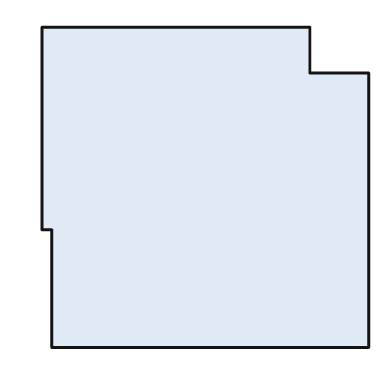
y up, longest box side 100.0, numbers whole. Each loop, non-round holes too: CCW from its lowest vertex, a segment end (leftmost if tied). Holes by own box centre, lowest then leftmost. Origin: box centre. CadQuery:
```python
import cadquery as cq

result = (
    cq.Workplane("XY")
    .moveTo(-47.0, -49.0)
    .lineTo(50.0, -49.0)
    .lineTo(50.0, 35.0)
    .lineTo(32.0, 35.0)
    .lineTo(32.0, 49.0)
    .lineTo(-50.0, 49.0)
    .lineTo(-50.0, -13.0)
    .lineTo(-47.0, -13.0)
    .close()
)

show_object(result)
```